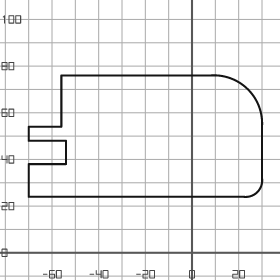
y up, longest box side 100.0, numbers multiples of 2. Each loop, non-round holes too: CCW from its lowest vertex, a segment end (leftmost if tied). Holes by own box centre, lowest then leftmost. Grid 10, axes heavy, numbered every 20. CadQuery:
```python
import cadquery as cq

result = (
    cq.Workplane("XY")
    .moveTo(-70.0, 24.0)
    .lineTo(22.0, 24.0)
    .threePointArc((28.0, 26.0), (30.0, 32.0))
    .lineTo(30.0, 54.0)
    .threePointArc((24.0, 70.0), (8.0, 76.0))
    .lineTo(-56.0, 76.0)
    .lineTo(-56.0, 54.0)
    .lineTo(-70.0, 54.0)
    .lineTo(-70.0, 48.0)
    .lineTo(-54.0, 48.0)
    .lineTo(-54.0, 38.0)
    .lineTo(-70.0, 38.0)
    .close()
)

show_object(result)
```